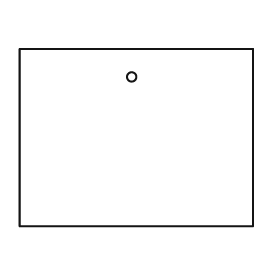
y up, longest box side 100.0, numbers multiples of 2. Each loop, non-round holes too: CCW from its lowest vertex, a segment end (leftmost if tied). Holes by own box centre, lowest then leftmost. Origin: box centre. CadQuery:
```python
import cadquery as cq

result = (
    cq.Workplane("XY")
    .moveTo(-50.0, -38.0)
    .lineTo(50.0, -38.0)
    .lineTo(50.0, 38.0)
    .lineTo(-50.0, 38.0)
    .close()
    .moveTo(-2.0, 26.0)
    .circle(2.0)
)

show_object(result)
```